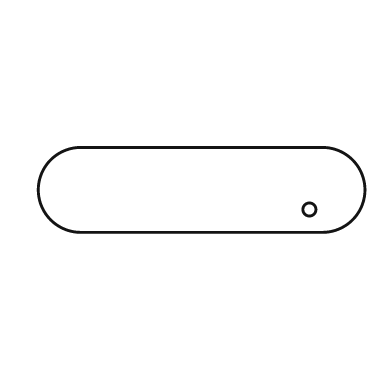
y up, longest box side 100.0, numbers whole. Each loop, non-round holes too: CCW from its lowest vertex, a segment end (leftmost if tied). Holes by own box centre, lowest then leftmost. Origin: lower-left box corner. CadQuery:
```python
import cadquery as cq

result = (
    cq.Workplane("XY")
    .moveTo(13.0, 0.0)
    .lineTo(87.0, 0.0)
    .threePointArc((100.0, 13.0), (87.0, 26.0))
    .lineTo(13.0, 26.0)
    .threePointArc((0.0, 13.0), (13.0, 0.0))
    .close()
    .moveTo(83.0, 7.0)
    .circle(2.0)
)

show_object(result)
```